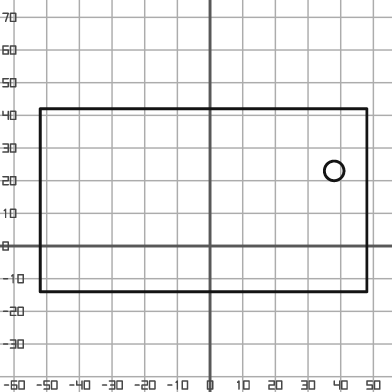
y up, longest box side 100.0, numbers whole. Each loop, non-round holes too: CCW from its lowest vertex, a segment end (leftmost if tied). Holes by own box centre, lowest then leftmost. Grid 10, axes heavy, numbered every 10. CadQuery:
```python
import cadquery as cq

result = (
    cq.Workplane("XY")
    .moveTo(-52.0, -14.0)
    .lineTo(48.0, -14.0)
    .lineTo(48.0, 42.0)
    .lineTo(-52.0, 42.0)
    .close()
    .moveTo(38.0, 23.0)
    .circle(3.0)
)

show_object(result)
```